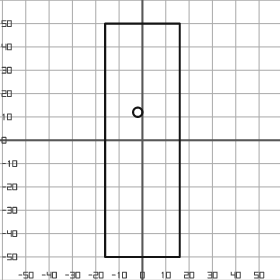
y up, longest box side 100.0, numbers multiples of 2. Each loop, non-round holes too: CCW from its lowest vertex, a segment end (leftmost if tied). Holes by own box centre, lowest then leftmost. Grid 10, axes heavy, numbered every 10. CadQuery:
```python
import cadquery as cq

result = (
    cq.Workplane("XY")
    .moveTo(-16.0, -50.0)
    .lineTo(16.0, -50.0)
    .lineTo(16.0, 50.0)
    .lineTo(-16.0, 50.0)
    .close()
    .moveTo(-2.0, 12.0)
    .circle(2.0)
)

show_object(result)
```